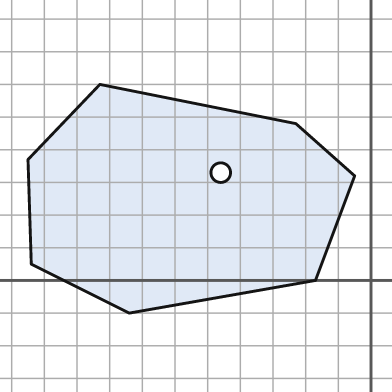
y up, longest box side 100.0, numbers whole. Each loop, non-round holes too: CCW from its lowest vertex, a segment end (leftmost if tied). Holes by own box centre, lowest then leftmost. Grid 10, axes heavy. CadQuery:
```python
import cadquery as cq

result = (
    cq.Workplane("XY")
    .moveTo(-74.0, -10.0)
    .lineTo(-17.0, 0.0)
    .lineTo(-5.0, 32.0)
    .lineTo(-23.0, 48.0)
    .lineTo(-83.0, 60.0)
    .lineTo(-105.0, 37.0)
    .lineTo(-104.0, 5.0)
    .close()
    .moveTo(-46.0, 33.0)
    .circle(3.0)
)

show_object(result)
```